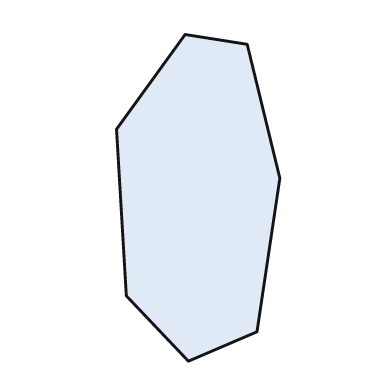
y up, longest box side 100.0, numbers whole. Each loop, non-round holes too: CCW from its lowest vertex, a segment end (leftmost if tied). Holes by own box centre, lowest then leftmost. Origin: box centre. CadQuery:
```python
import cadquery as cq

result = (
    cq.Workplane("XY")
    .moveTo(-3.0, -50.0)
    .lineTo(18.0, -41.0)
    .lineTo(25.0, 6.0)
    .lineTo(15.0, 47.0)
    .lineTo(-4.0, 50.0)
    .lineTo(-25.0, 21.0)
    .lineTo(-22.0, -30.0)
    .close()
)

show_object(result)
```